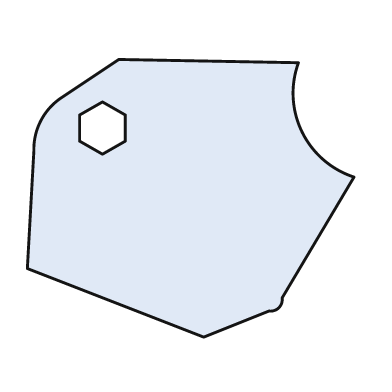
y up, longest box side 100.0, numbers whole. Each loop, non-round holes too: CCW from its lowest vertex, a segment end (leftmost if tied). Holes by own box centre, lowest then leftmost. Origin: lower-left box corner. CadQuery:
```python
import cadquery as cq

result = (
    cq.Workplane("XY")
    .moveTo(54.0, 0.0)
    .lineTo(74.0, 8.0)
    .threePointArc((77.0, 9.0), (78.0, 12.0))
    .lineTo(100.0, 49.0)
    .threePointArc((84.0, 63.0), (83.0, 84.0))
    .lineTo(28.0, 85.0)
    .lineTo(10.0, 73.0)
    .threePointArc((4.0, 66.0), (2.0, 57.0))
    .lineTo(0.0, 21.0)
    .close()
    .moveTo(23.0, 56.0)
    .lineTo(30.0, 60.0)
    .lineTo(30.0, 68.0)
    .lineTo(23.0, 72.0)
    .lineTo(16.0, 68.0)
    .lineTo(16.0, 60.0)
    .close()
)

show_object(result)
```